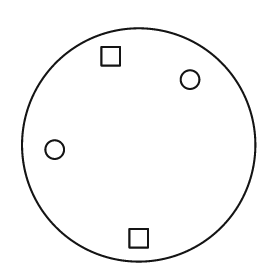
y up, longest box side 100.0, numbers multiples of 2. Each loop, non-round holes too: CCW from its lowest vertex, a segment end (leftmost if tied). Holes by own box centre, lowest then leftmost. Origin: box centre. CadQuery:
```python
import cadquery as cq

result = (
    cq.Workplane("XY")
    .moveTo(0.0, 0.0)
    .circle(50.0)
    .moveTo(-4.0, -44.0)
    .lineTo(4.0, -44.0)
    .lineTo(4.0, -36.0)
    .lineTo(-4.0, -36.0)
    .close()
    .moveTo(-36.0, -2.0)
    .circle(4.0)
    .moveTo(22.0, 28.0)
    .circle(4.0)
    .moveTo(-16.0, 34.0)
    .lineTo(-8.0, 34.0)
    .lineTo(-8.0, 42.0)
    .lineTo(-16.0, 42.0)
    .close()
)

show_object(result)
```